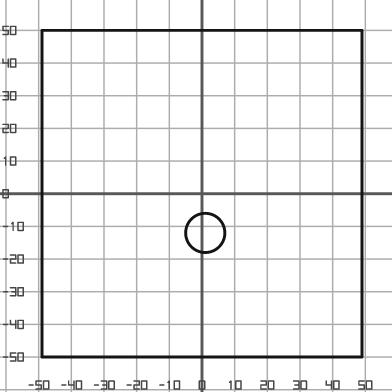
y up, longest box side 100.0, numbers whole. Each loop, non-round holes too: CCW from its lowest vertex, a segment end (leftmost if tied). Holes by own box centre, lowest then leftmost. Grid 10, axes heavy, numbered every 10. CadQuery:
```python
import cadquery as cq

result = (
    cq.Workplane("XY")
    .moveTo(-49.0, -50.0)
    .lineTo(49.0, -50.0)
    .lineTo(49.0, 50.0)
    .lineTo(-49.0, 50.0)
    .close()
    .moveTo(1.0, -12.0)
    .circle(6.0)
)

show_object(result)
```